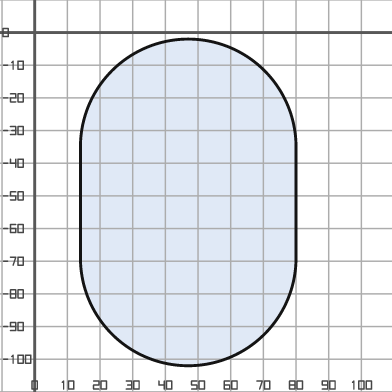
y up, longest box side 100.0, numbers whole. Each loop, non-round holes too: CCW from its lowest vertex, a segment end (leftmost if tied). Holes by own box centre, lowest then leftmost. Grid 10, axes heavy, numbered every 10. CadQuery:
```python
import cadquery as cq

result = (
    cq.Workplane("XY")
    .moveTo(14.0, -69.0)
    .threePointArc((47.0, -102.0), (80.0, -69.0))
    .lineTo(80.0, -35.0)
    .threePointArc((47.0, -2.0), (14.0, -35.0))
    .close()
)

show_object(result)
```